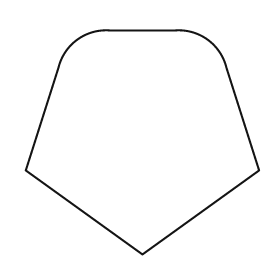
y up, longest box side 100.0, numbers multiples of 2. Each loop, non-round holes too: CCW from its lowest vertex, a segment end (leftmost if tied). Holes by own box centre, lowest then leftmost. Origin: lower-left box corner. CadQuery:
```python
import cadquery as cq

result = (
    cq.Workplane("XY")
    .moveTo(50.0, 0.0)
    .lineTo(100.0, 36.0)
    .lineTo(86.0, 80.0)
    .threePointArc((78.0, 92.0), (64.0, 96.0))
    .lineTo(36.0, 96.0)
    .threePointArc((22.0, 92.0), (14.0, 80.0))
    .lineTo(0.0, 36.0)
    .close()
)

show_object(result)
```